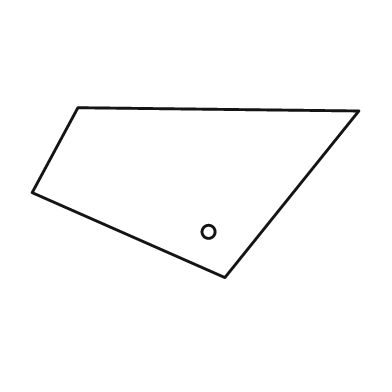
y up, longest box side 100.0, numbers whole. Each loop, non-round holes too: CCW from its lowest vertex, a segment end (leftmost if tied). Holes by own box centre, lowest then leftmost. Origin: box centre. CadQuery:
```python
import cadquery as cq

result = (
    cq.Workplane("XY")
    .moveTo(9.0, -26.0)
    .lineTo(50.0, 25.0)
    .lineTo(-36.0, 26.0)
    .lineTo(-50.0, 0.0)
    .close()
    .moveTo(4.0, -12.0)
    .circle(2.0)
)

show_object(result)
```